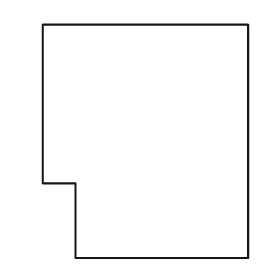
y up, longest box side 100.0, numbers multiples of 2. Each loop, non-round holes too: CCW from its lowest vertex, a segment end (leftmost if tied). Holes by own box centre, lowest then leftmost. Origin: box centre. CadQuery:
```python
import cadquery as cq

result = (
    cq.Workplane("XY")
    .moveTo(-30.0, -50.0)
    .lineTo(44.0, -50.0)
    .lineTo(44.0, 50.0)
    .lineTo(-44.0, 50.0)
    .lineTo(-44.0, -18.0)
    .lineTo(-30.0, -18.0)
    .close()
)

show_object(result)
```